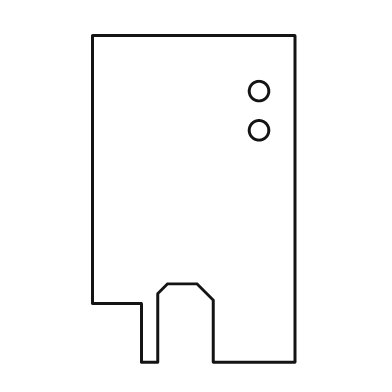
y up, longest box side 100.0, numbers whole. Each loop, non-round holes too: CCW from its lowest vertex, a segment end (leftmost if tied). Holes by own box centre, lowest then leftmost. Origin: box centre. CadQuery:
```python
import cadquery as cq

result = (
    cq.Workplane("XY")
    .moveTo(-16.0, -50.0)
    .lineTo(-11.0, -50.0)
    .lineTo(-11.0, -29.0)
    .lineTo(-8.0, -26.0)
    .lineTo(1.0, -26.0)
    .lineTo(6.0, -31.0)
    .lineTo(6.0, -50.0)
    .lineTo(31.0, -50.0)
    .lineTo(31.0, 50.0)
    .lineTo(-31.0, 50.0)
    .lineTo(-31.0, -32.0)
    .lineTo(-16.0, -32.0)
    .close()
    .moveTo(20.0, 21.0)
    .circle(3.0)
    .moveTo(20.0, 33.0)
    .circle(3.0)
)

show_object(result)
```